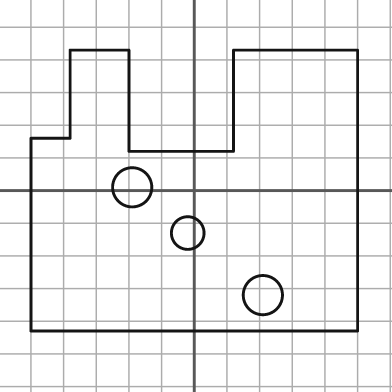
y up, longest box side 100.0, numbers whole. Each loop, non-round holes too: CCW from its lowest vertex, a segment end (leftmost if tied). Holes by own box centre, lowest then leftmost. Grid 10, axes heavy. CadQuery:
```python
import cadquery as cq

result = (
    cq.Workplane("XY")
    .moveTo(-50.0, -43.0)
    .lineTo(50.0, -43.0)
    .lineTo(50.0, 43.0)
    .lineTo(12.0, 43.0)
    .lineTo(12.0, 12.0)
    .lineTo(-20.0, 12.0)
    .lineTo(-20.0, 43.0)
    .lineTo(-38.0, 43.0)
    .lineTo(-38.0, 16.0)
    .lineTo(-50.0, 16.0)
    .close()
    .moveTo(21.0, -32.0)
    .circle(6.0)
    .moveTo(-2.0, -13.0)
    .circle(5.0)
    .moveTo(-19.0, 1.0)
    .circle(6.0)
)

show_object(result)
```